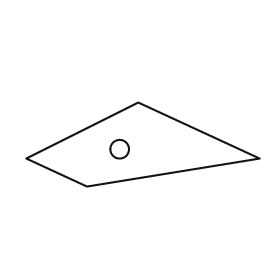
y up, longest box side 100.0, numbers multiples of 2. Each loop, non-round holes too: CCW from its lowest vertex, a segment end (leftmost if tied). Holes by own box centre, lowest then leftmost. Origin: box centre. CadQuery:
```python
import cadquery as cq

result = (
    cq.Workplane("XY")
    .moveTo(-24.0, -18.0)
    .lineTo(50.0, -6.0)
    .lineTo(-2.0, 18.0)
    .lineTo(-50.0, -6.0)
    .close()
    .moveTo(-10.0, -2.0)
    .circle(4.0)
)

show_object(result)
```